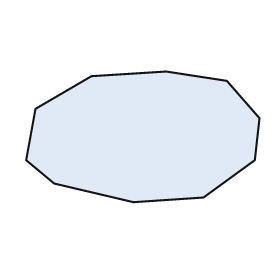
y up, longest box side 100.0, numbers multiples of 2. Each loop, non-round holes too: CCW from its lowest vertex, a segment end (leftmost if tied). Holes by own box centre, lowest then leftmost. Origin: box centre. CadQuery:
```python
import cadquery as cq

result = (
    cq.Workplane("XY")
    .moveTo(-4.0, -28.0)
    .lineTo(26.0, -26.0)
    .lineTo(48.0, -10.0)
    .lineTo(50.0, 8.0)
    .lineTo(36.0, 24.0)
    .lineTo(10.0, 28.0)
    .lineTo(-22.0, 26.0)
    .lineTo(-46.0, 12.0)
    .lineTo(-50.0, -10.0)
    .lineTo(-38.0, -20.0)
    .close()
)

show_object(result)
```